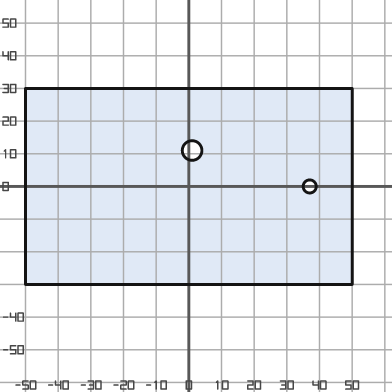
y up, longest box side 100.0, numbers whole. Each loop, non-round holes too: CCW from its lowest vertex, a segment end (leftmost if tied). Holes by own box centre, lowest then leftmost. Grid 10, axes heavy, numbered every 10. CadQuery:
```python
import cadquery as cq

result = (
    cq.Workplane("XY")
    .moveTo(-50.0, -30.0)
    .lineTo(50.0, -30.0)
    .lineTo(50.0, 30.0)
    .lineTo(-50.0, 30.0)
    .close()
    .moveTo(37.0, 0.0)
    .circle(2.0)
    .moveTo(1.0, 11.0)
    .circle(3.0)
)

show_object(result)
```